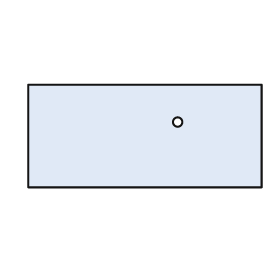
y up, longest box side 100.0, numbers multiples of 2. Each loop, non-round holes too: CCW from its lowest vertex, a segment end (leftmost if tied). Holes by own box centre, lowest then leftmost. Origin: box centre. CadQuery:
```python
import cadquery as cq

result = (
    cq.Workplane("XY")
    .moveTo(-50.0, -22.0)
    .lineTo(50.0, -22.0)
    .lineTo(50.0, 22.0)
    .lineTo(-50.0, 22.0)
    .close()
    .moveTo(14.0, 6.0)
    .circle(2.0)
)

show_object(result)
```